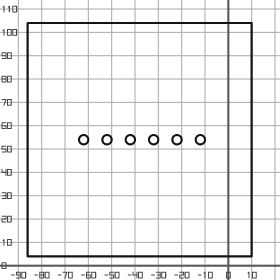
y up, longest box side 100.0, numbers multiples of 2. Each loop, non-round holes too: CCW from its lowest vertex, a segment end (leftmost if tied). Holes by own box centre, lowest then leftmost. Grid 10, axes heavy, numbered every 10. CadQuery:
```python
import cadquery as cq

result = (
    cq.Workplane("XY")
    .moveTo(-86.0, 4.0)
    .lineTo(10.0, 4.0)
    .lineTo(10.0, 104.0)
    .lineTo(-86.0, 104.0)
    .close()
    .moveTo(-62.0, 54.0)
    .circle(2.0)
    .moveTo(-52.0, 54.0)
    .circle(2.0)
    .moveTo(-42.0, 54.0)
    .circle(2.0)
    .moveTo(-32.0, 54.0)
    .circle(2.0)
    .moveTo(-22.0, 54.0)
    .circle(2.0)
    .moveTo(-12.0, 54.0)
    .circle(2.0)
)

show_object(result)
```